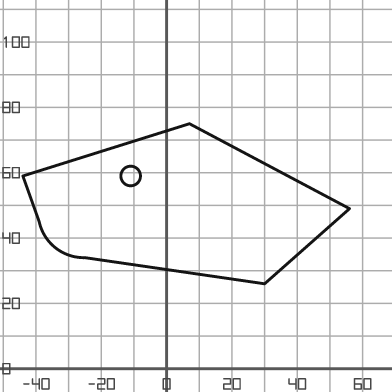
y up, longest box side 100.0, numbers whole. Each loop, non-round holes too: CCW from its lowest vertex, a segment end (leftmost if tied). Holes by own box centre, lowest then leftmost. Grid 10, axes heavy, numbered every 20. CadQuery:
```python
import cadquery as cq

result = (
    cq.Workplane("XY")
    .moveTo(30.0, 26.0)
    .lineTo(56.0, 49.0)
    .lineTo(7.0, 75.0)
    .lineTo(-44.0, 59.0)
    .lineTo(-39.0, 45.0)
    .threePointArc((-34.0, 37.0), (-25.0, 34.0))
    .close()
    .moveTo(-11.0, 59.0)
    .circle(3.0)
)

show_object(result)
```